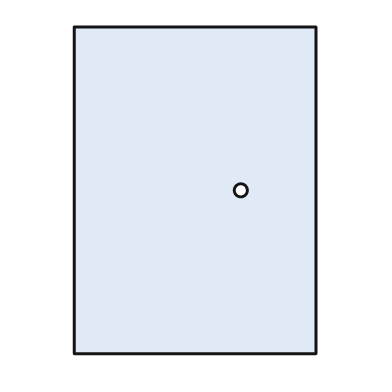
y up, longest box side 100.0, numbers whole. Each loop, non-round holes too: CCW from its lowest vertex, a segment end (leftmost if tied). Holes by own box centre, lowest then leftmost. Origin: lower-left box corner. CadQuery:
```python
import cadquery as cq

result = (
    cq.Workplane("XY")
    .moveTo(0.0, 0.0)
    .lineTo(74.0, 0.0)
    .lineTo(74.0, 100.0)
    .lineTo(0.0, 100.0)
    .close()
    .moveTo(51.0, 50.0)
    .circle(2.0)
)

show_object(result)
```